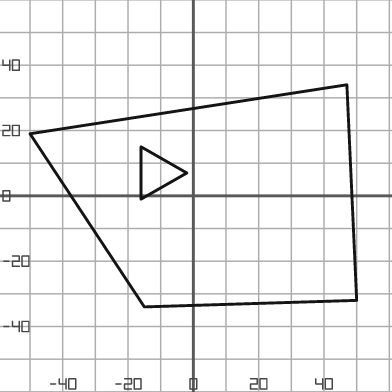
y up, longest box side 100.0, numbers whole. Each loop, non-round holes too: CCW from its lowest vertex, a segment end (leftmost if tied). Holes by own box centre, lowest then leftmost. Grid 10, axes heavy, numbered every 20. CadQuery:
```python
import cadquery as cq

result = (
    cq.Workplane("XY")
    .moveTo(-15.0, -34.0)
    .lineTo(50.0, -32.0)
    .lineTo(47.0, 34.0)
    .lineTo(-50.0, 19.0)
    .close()
    .moveTo(-16.0, -1.0)
    .lineTo(-2.0, 7.0)
    .lineTo(-16.0, 15.0)
    .close()
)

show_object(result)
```